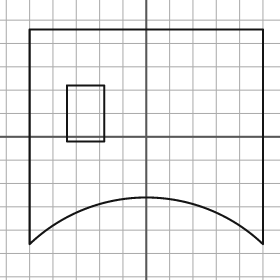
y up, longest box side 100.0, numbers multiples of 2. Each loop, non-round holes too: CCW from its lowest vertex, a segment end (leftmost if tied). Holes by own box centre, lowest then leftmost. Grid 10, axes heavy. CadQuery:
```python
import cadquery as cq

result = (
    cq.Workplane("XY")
    .moveTo(-50.0, -46.0)
    .threePointArc((0.0, -26.0), (50.0, -46.0))
    .lineTo(50.0, 46.0)
    .lineTo(-50.0, 46.0)
    .close()
    .moveTo(-34.0, -2.0)
    .lineTo(-18.0, -2.0)
    .lineTo(-18.0, 22.0)
    .lineTo(-34.0, 22.0)
    .close()
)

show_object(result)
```